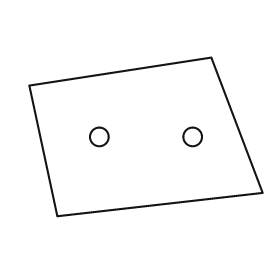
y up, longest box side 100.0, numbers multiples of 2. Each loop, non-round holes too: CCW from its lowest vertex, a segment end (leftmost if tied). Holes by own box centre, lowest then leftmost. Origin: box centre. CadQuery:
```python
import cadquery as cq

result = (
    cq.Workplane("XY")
    .moveTo(-38.0, -34.0)
    .lineTo(50.0, -24.0)
    .lineTo(28.0, 34.0)
    .lineTo(-50.0, 22.0)
    .close()
    .moveTo(-20.0, 0.0)
    .circle(4.0)
    .moveTo(20.0, 0.0)
    .circle(4.0)
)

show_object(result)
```